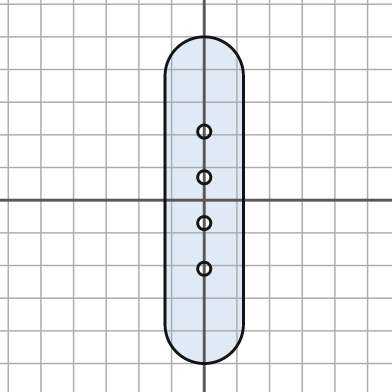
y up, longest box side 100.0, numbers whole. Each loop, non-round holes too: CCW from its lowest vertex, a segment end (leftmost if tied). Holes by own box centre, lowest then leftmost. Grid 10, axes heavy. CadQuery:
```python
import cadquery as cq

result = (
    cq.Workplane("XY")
    .moveTo(-12.0, -38.0)
    .threePointArc((0.0, -50.0), (12.0, -38.0))
    .lineTo(12.0, 38.0)
    .threePointArc((0.0, 50.0), (-12.0, 38.0))
    .close()
    .moveTo(0.0, -21.0)
    .circle(2.0)
    .moveTo(0.0, -7.0)
    .circle(2.0)
    .moveTo(0.0, 7.0)
    .circle(2.0)
    .moveTo(0.0, 21.0)
    .circle(2.0)
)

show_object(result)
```